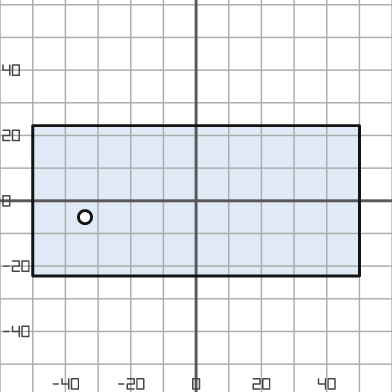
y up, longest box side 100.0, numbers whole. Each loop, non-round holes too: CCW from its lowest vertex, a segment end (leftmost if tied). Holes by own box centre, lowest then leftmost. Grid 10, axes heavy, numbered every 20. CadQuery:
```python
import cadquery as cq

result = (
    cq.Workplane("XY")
    .moveTo(-50.0, -23.0)
    .lineTo(50.0, -23.0)
    .lineTo(50.0, 23.0)
    .lineTo(-50.0, 23.0)
    .close()
    .moveTo(-34.0, -5.0)
    .circle(2.0)
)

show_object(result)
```